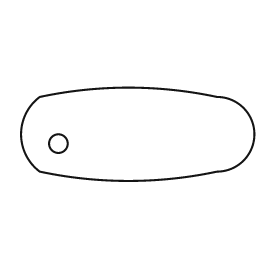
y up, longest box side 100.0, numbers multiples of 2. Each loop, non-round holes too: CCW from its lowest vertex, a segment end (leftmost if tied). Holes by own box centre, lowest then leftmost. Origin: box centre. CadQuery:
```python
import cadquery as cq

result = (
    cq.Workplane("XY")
    .moveTo(-42.0, -16.0)
    .threePointArc((-4.0, -20.0), (34.0, -16.0))
    .threePointArc((50.0, 0.0), (34.0, 16.0))
    .threePointArc((-4.0, 20.0), (-42.0, 16.0))
    .threePointArc((-50.0, 0.0), (-42.0, -16.0))
    .close()
    .moveTo(-34.0, -4.0)
    .circle(4.0)
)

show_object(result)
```